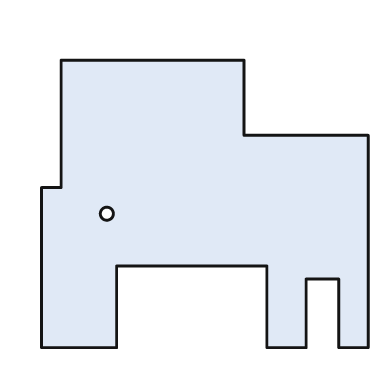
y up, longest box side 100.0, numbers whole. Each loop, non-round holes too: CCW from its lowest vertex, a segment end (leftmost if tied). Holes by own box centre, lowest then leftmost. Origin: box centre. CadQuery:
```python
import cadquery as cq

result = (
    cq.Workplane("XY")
    .moveTo(-50.0, -44.0)
    .lineTo(-27.0, -44.0)
    .lineTo(-27.0, -19.0)
    .lineTo(19.0, -19.0)
    .lineTo(19.0, -44.0)
    .lineTo(31.0, -44.0)
    .lineTo(31.0, -23.0)
    .lineTo(41.0, -23.0)
    .lineTo(41.0, -44.0)
    .lineTo(50.0, -44.0)
    .lineTo(50.0, 21.0)
    .lineTo(12.0, 21.0)
    .lineTo(12.0, 44.0)
    .lineTo(-44.0, 44.0)
    .lineTo(-44.0, 5.0)
    .lineTo(-50.0, 5.0)
    .close()
    .moveTo(-30.0, -3.0)
    .circle(2.0)
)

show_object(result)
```